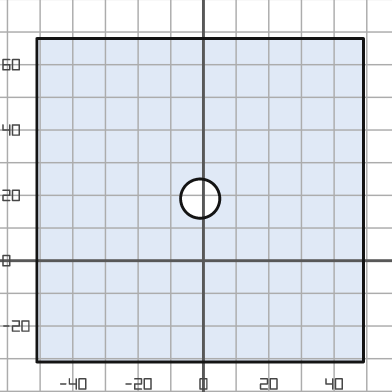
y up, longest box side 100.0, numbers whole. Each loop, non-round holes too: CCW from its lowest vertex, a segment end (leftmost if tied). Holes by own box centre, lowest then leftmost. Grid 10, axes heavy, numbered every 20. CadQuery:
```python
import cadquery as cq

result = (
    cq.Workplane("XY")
    .moveTo(-51.0, -31.0)
    .lineTo(49.0, -31.0)
    .lineTo(49.0, 68.0)
    .lineTo(-51.0, 68.0)
    .close()
    .moveTo(-1.0, 19.0)
    .circle(6.0)
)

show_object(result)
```